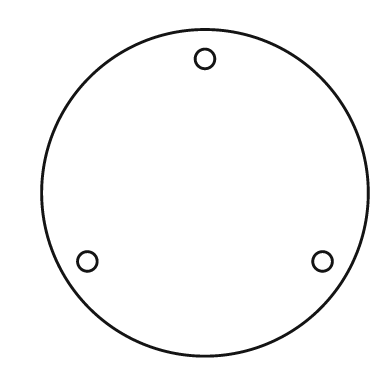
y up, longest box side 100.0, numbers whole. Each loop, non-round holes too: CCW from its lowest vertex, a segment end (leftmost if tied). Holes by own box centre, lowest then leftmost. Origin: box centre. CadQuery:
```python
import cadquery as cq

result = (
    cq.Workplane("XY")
    .moveTo(0.0, 0.0)
    .circle(50.0)
    .moveTo(-36.0, -21.0)
    .circle(3.0)
    .moveTo(36.0, -21.0)
    .circle(3.0)
    .moveTo(0.0, 41.0)
    .circle(3.0)
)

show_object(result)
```